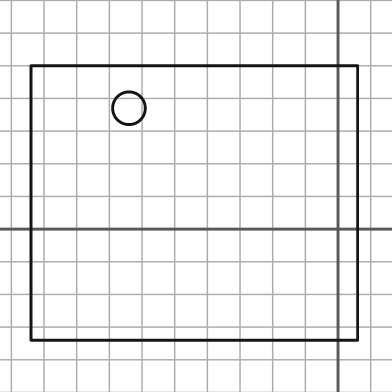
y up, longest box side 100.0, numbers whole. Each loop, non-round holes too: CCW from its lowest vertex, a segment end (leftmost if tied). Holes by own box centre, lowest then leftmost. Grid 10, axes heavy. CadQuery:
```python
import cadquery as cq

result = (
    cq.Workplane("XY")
    .moveTo(-94.0, -34.0)
    .lineTo(6.0, -34.0)
    .lineTo(6.0, 50.0)
    .lineTo(-94.0, 50.0)
    .close()
    .moveTo(-64.0, 37.0)
    .circle(5.0)
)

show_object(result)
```